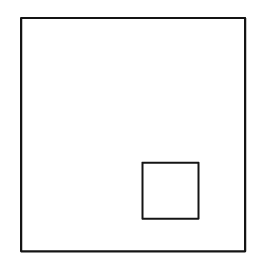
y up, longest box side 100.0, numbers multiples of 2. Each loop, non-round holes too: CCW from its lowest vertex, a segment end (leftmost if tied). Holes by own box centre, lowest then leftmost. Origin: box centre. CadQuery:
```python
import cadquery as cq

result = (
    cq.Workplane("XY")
    .moveTo(-48.0, -50.0)
    .lineTo(48.0, -50.0)
    .lineTo(48.0, 50.0)
    .lineTo(-48.0, 50.0)
    .close()
    .moveTo(4.0, -36.0)
    .lineTo(28.0, -36.0)
    .lineTo(28.0, -12.0)
    .lineTo(4.0, -12.0)
    .close()
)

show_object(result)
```